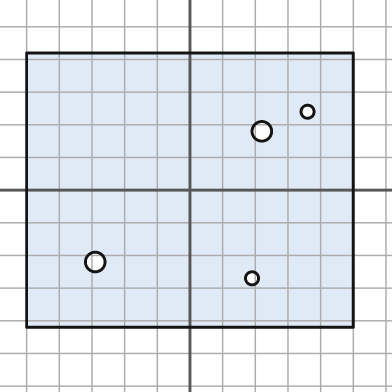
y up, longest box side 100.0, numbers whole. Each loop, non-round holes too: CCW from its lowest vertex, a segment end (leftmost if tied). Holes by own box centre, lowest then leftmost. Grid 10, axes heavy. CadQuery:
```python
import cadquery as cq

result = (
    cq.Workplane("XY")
    .moveTo(-50.0, -42.0)
    .lineTo(50.0, -42.0)
    .lineTo(50.0, 42.0)
    .lineTo(-50.0, 42.0)
    .close()
    .moveTo(19.0, -27.0)
    .circle(2.0)
    .moveTo(-29.0, -22.0)
    .circle(3.0)
    .moveTo(22.0, 18.0)
    .circle(3.0)
    .moveTo(36.0, 24.0)
    .circle(2.0)
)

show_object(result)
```